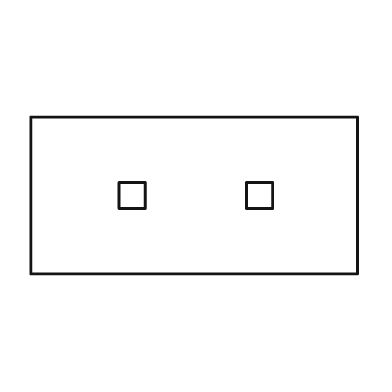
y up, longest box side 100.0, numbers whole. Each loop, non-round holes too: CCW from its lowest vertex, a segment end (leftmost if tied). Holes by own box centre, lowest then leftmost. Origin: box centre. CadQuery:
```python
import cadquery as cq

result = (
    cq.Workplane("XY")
    .moveTo(-50.0, -24.0)
    .lineTo(50.0, -24.0)
    .lineTo(50.0, 24.0)
    .lineTo(-50.0, 24.0)
    .close()
    .moveTo(-23.0, -4.0)
    .lineTo(-15.0, -4.0)
    .lineTo(-15.0, 4.0)
    .lineTo(-23.0, 4.0)
    .close()
    .moveTo(16.0, -4.0)
    .lineTo(24.0, -4.0)
    .lineTo(24.0, 4.0)
    .lineTo(16.0, 4.0)
    .close()
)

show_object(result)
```